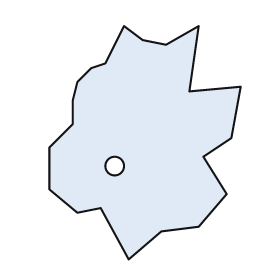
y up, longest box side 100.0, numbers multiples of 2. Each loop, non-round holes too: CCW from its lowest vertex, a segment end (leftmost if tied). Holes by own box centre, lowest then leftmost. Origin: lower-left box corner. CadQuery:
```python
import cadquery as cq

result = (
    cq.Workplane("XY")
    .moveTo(34.0, 0.0)
    .lineTo(48.0, 12.0)
    .lineTo(64.0, 14.0)
    .lineTo(76.0, 28.0)
    .lineTo(66.0, 44.0)
    .lineTo(78.0, 52.0)
    .lineTo(82.0, 74.0)
    .lineTo(60.0, 72.0)
    .lineTo(64.0, 100.0)
    .lineTo(50.0, 92.0)
    .lineTo(40.0, 94.0)
    .lineTo(32.0, 100.0)
    .lineTo(24.0, 84.0)
    .lineTo(18.0, 82.0)
    .lineTo(12.0, 76.0)
    .lineTo(10.0, 68.0)
    .lineTo(10.0, 58.0)
    .lineTo(0.0, 48.0)
    .lineTo(0.0, 30.0)
    .lineTo(12.0, 20.0)
    .lineTo(22.0, 22.0)
    .close()
    .moveTo(28.0, 40.0)
    .circle(4.0)
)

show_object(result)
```